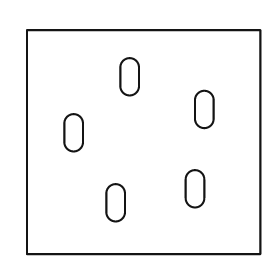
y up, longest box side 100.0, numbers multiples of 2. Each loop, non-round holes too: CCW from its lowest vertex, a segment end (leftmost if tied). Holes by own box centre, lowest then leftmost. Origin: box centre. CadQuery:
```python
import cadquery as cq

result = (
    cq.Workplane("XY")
    .moveTo(-50.0, -48.0)
    .lineTo(50.0, -48.0)
    .lineTo(50.0, 48.0)
    .lineTo(-50.0, 48.0)
    .close()
    .moveTo(-16.0, -30.0)
    .threePointArc((-12.0, -34.0), (-8.0, -30.0))
    .lineTo(-8.0, -22.0)
    .threePointArc((-12.0, -18.0), (-16.0, -22.0))
    .close()
    .moveTo(18.0, -24.0)
    .threePointArc((22.0, -28.0), (26.0, -24.0))
    .lineTo(26.0, -16.0)
    .threePointArc((22.0, -12.0), (18.0, -16.0))
    .close()
    .moveTo(-34.0, 0.0)
    .threePointArc((-30.0, -4.0), (-26.0, 0.0))
    .lineTo(-26.0, 8.0)
    .threePointArc((-30.0, 12.0), (-34.0, 8.0))
    .close()
    .moveTo(22.0, 10.0)
    .threePointArc((26.0, 6.0), (30.0, 10.0))
    .lineTo(30.0, 18.0)
    .threePointArc((26.0, 22.0), (22.0, 18.0))
    .close()
    .moveTo(-10.0, 24.0)
    .threePointArc((-6.0, 20.0), (-2.0, 24.0))
    .lineTo(-2.0, 32.0)
    .threePointArc((-6.0, 36.0), (-10.0, 32.0))
    .close()
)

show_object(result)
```